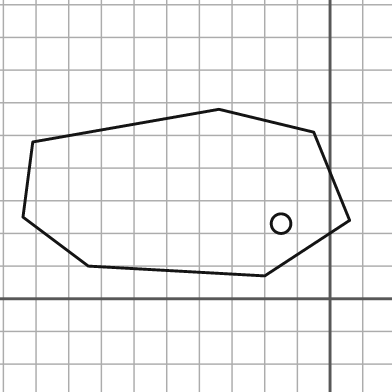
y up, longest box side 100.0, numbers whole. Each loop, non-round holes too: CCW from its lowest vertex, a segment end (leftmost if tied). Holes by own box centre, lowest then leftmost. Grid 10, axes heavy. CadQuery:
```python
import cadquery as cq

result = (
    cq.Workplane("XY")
    .moveTo(-20.0, 7.0)
    .lineTo(6.0, 24.0)
    .lineTo(-5.0, 51.0)
    .lineTo(-34.0, 58.0)
    .lineTo(-91.0, 48.0)
    .lineTo(-94.0, 25.0)
    .lineTo(-74.0, 10.0)
    .close()
    .moveTo(-15.0, 23.0)
    .circle(3.0)
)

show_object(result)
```